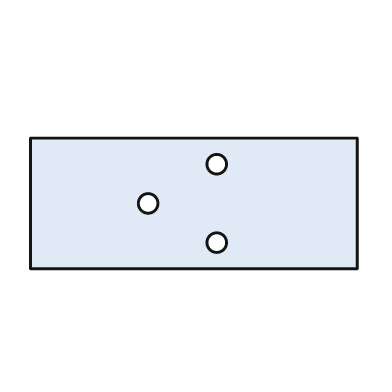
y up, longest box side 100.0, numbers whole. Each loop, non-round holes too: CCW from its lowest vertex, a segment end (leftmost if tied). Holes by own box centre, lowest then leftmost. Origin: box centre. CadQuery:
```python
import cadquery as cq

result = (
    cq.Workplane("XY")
    .moveTo(-50.0, -20.0)
    .lineTo(50.0, -20.0)
    .lineTo(50.0, 20.0)
    .lineTo(-50.0, 20.0)
    .close()
    .moveTo(7.0, -12.0)
    .circle(3.0)
    .moveTo(-14.0, 0.0)
    .circle(3.0)
    .moveTo(7.0, 12.0)
    .circle(3.0)
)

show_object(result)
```